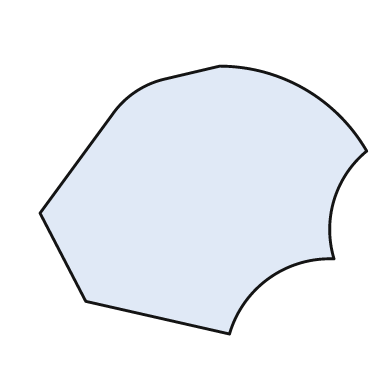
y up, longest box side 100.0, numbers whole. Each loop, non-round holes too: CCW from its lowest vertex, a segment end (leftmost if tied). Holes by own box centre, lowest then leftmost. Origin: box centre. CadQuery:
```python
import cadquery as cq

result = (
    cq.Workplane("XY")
    .moveTo(8.0, -41.0)
    .threePointArc((20.0, -24.0), (40.0, -18.0))
    .threePointArc((40.0, 0.0), (50.0, 15.0))
    .threePointArc((31.0, 34.0), (5.0, 41.0))
    .lineTo(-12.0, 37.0)
    .threePointArc((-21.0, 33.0), (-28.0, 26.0))
    .lineTo(-50.0, -4.0)
    .lineTo(-36.0, -31.0)
    .close()
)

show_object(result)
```